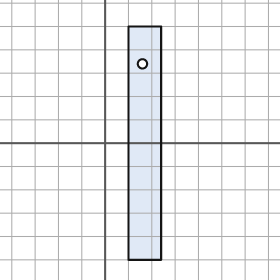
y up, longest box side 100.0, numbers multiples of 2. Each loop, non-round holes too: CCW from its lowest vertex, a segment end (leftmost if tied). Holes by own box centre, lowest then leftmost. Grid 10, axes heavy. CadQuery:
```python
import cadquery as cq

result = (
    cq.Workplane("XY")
    .moveTo(10.0, -50.0)
    .lineTo(24.0, -50.0)
    .lineTo(24.0, 50.0)
    .lineTo(10.0, 50.0)
    .close()
    .moveTo(16.0, 34.0)
    .circle(2.0)
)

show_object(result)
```